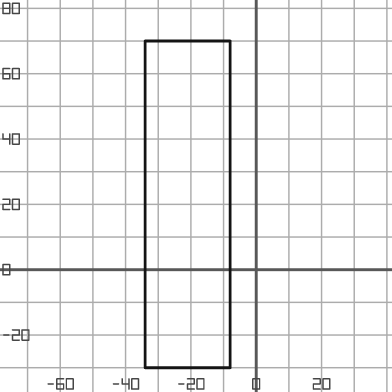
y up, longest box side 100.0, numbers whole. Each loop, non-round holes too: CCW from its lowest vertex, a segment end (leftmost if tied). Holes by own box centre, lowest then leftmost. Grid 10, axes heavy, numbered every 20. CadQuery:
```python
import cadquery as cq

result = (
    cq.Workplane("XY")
    .moveTo(-34.0, -30.0)
    .lineTo(-8.0, -30.0)
    .lineTo(-8.0, 70.0)
    .lineTo(-34.0, 70.0)
    .close()
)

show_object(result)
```